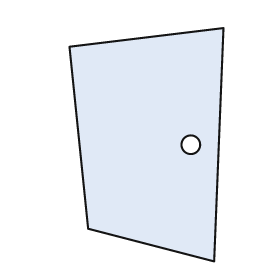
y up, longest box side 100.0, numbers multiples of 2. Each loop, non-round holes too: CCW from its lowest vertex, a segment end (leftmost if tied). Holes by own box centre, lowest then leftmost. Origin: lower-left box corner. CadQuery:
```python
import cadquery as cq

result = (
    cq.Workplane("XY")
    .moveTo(62.0, 0.0)
    .lineTo(66.0, 100.0)
    .lineTo(0.0, 92.0)
    .lineTo(8.0, 14.0)
    .close()
    .moveTo(52.0, 50.0)
    .circle(4.0)
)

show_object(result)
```